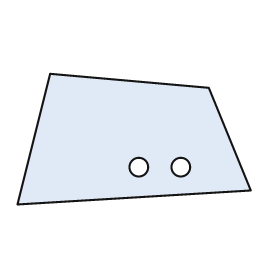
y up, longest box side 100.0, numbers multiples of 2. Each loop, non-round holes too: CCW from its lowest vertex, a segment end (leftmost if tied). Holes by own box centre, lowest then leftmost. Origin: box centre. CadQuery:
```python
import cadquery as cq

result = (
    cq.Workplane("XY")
    .moveTo(-50.0, -28.0)
    .lineTo(50.0, -22.0)
    .lineTo(32.0, 22.0)
    .lineTo(-36.0, 28.0)
    .close()
    .moveTo(2.0, -12.0)
    .circle(4.0)
    .moveTo(20.0, -12.0)
    .circle(4.0)
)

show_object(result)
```